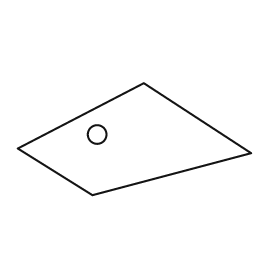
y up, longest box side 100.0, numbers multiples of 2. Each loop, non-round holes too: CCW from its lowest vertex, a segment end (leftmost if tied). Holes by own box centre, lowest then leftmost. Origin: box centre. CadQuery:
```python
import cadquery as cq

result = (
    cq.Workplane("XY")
    .moveTo(-18.0, -24.0)
    .lineTo(50.0, -6.0)
    .lineTo(4.0, 24.0)
    .lineTo(-50.0, -4.0)
    .close()
    .moveTo(-16.0, 2.0)
    .circle(4.0)
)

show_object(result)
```